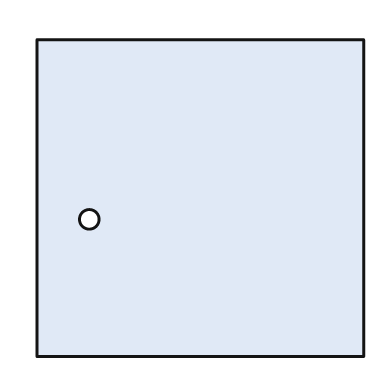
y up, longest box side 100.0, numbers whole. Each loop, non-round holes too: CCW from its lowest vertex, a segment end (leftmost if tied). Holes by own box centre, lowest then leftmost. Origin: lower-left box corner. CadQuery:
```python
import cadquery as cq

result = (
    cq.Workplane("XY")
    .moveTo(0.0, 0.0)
    .lineTo(100.0, 0.0)
    .lineTo(100.0, 97.0)
    .lineTo(0.0, 97.0)
    .close()
    .moveTo(16.0, 42.0)
    .circle(3.0)
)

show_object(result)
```